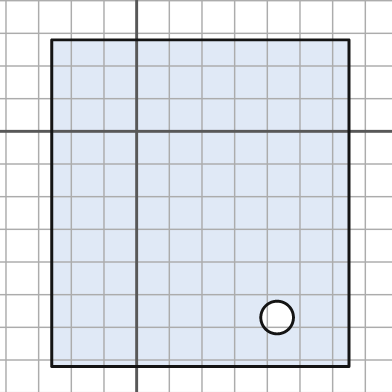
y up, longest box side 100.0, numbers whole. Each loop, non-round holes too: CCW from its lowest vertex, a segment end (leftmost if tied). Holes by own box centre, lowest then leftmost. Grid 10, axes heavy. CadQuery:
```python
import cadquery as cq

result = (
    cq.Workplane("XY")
    .moveTo(-26.0, -72.0)
    .lineTo(65.0, -72.0)
    .lineTo(65.0, 28.0)
    .lineTo(-26.0, 28.0)
    .close()
    .moveTo(43.0, -57.0)
    .circle(5.0)
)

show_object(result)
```